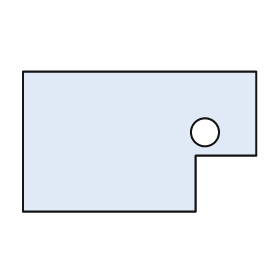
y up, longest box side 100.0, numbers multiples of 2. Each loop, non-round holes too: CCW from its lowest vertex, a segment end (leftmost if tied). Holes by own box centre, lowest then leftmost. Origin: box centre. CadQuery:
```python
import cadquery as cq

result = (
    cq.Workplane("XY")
    .moveTo(-50.0, -30.0)
    .lineTo(24.0, -30.0)
    .lineTo(24.0, -6.0)
    .lineTo(50.0, -6.0)
    .lineTo(50.0, 30.0)
    .lineTo(-50.0, 30.0)
    .close()
    .moveTo(28.0, 4.0)
    .circle(6.0)
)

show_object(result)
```